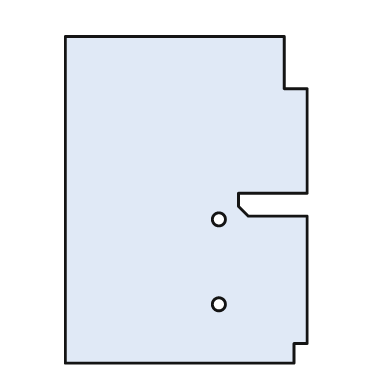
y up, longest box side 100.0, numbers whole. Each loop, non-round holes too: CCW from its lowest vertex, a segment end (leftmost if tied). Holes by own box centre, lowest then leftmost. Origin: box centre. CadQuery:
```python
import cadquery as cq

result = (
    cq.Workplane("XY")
    .moveTo(-37.0, -50.0)
    .lineTo(33.0, -50.0)
    .lineTo(33.0, -44.0)
    .lineTo(37.0, -44.0)
    .lineTo(37.0, -5.0)
    .lineTo(19.0, -5.0)
    .lineTo(16.0, -2.0)
    .lineTo(16.0, 2.0)
    .lineTo(37.0, 2.0)
    .lineTo(37.0, 34.0)
    .lineTo(30.0, 34.0)
    .lineTo(30.0, 50.0)
    .lineTo(-37.0, 50.0)
    .close()
    .moveTo(10.0, -32.0)
    .circle(2.0)
    .moveTo(10.0, -6.0)
    .circle(2.0)
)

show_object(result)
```